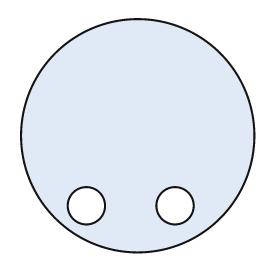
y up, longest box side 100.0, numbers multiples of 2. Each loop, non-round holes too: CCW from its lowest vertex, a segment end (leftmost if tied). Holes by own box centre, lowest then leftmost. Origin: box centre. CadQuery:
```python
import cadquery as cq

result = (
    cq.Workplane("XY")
    .moveTo(0.0, 0.0)
    .circle(50.0)
    .moveTo(-22.0, -30.0)
    .circle(8.0)
    .moveTo(16.0, -30.0)
    .circle(8.0)
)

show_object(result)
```